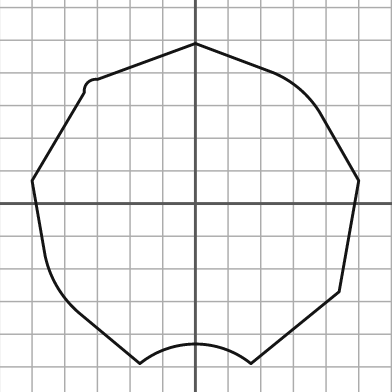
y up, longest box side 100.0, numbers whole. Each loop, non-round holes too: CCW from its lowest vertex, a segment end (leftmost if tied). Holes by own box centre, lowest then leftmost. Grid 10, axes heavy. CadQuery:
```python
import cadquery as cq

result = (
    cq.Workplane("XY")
    .moveTo(-17.0, -49.0)
    .threePointArc((0.0, -43.0), (17.0, -49.0))
    .lineTo(44.0, -27.0)
    .lineTo(50.0, 7.0)
    .lineTo(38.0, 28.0)
    .threePointArc((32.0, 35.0), (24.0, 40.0))
    .lineTo(0.0, 49.0)
    .lineTo(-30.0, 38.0)
    .threePointArc((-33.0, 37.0), (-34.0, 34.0))
    .lineTo(-50.0, 7.0)
    .lineTo(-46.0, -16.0)
    .threePointArc((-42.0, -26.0), (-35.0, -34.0))
    .close()
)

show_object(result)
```